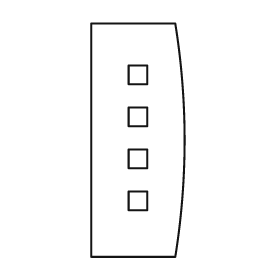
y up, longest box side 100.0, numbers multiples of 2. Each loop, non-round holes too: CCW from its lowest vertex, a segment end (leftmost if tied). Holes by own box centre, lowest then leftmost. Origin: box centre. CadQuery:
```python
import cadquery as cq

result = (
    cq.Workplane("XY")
    .moveTo(-20.0, -50.0)
    .lineTo(16.0, -50.0)
    .threePointArc((20.0, 0.0), (16.0, 50.0))
    .lineTo(-20.0, 50.0)
    .close()
    .moveTo(-4.0, -30.0)
    .lineTo(4.0, -30.0)
    .lineTo(4.0, -22.0)
    .lineTo(-4.0, -22.0)
    .close()
    .moveTo(-4.0, -12.0)
    .lineTo(4.0, -12.0)
    .lineTo(4.0, -4.0)
    .lineTo(-4.0, -4.0)
    .close()
    .moveTo(-4.0, 6.0)
    .lineTo(4.0, 6.0)
    .lineTo(4.0, 14.0)
    .lineTo(-4.0, 14.0)
    .close()
    .moveTo(-4.0, 24.0)
    .lineTo(4.0, 24.0)
    .lineTo(4.0, 32.0)
    .lineTo(-4.0, 32.0)
    .close()
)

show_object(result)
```